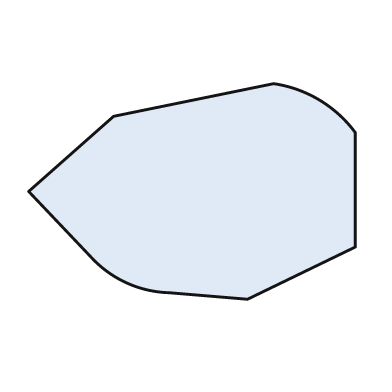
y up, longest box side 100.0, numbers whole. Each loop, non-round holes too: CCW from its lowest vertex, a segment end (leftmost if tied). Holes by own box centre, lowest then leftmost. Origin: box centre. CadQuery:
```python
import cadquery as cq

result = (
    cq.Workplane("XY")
    .moveTo(17.0, -33.0)
    .lineTo(50.0, -17.0)
    .lineTo(50.0, 18.0)
    .threePointArc((39.0, 28.0), (25.0, 33.0))
    .lineTo(-24.0, 23.0)
    .lineTo(-50.0, 0.0)
    .lineTo(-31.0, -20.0)
    .threePointArc((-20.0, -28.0), (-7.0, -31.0))
    .close()
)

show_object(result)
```